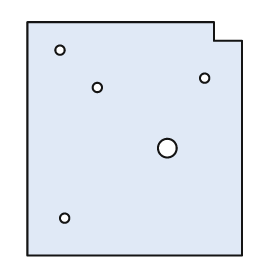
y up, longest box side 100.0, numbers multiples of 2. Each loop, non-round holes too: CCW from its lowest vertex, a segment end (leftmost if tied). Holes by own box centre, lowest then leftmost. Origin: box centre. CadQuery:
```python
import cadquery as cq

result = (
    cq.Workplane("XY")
    .moveTo(-46.0, -50.0)
    .lineTo(46.0, -50.0)
    .lineTo(46.0, 42.0)
    .lineTo(34.0, 42.0)
    .lineTo(34.0, 50.0)
    .lineTo(-46.0, 50.0)
    .close()
    .moveTo(-30.0, -34.0)
    .circle(2.0)
    .moveTo(14.0, -4.0)
    .circle(4.0)
    .moveTo(-16.0, 22.0)
    .circle(2.0)
    .moveTo(30.0, 26.0)
    .circle(2.0)
    .moveTo(-32.0, 38.0)
    .circle(2.0)
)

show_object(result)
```